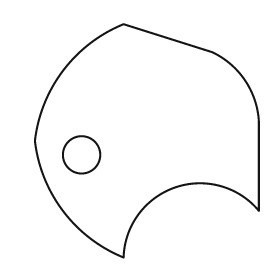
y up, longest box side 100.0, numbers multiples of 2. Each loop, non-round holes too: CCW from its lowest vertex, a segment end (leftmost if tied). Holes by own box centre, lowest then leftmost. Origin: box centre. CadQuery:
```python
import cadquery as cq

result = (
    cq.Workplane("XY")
    .moveTo(-10.0, -50.0)
    .threePointArc((12.0, -20.0), (48.0, -30.0))
    .lineTo(48.0, 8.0)
    .threePointArc((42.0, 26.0), (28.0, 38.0))
    .lineTo(-10.0, 50.0)
    .threePointArc((-36.0, 30.0), (-48.0, 0.0))
    .threePointArc((-36.0, -30.0), (-10.0, -50.0))
    .close()
    .moveTo(-28.0, -6.0)
    .circle(8.0)
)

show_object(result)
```